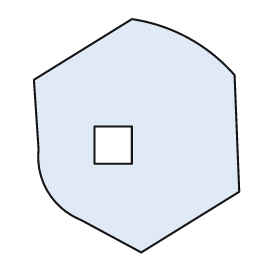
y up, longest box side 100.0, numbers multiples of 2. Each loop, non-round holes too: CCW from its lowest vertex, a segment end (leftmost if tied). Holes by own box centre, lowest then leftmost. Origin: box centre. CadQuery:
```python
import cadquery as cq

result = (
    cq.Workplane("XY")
    .moveTo(2.0, -50.0)
    .lineTo(44.0, -24.0)
    .lineTo(42.0, 26.0)
    .threePointArc((22.0, 42.0), (-2.0, 50.0))
    .lineTo(-44.0, 24.0)
    .lineTo(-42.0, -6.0)
    .threePointArc((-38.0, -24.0), (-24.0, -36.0))
    .close()
    .moveTo(-18.0, -12.0)
    .lineTo(-2.0, -12.0)
    .lineTo(-2.0, 4.0)
    .lineTo(-18.0, 4.0)
    .close()
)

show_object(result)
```